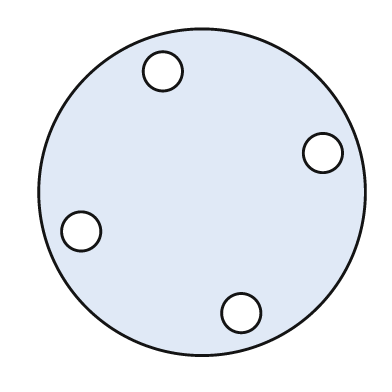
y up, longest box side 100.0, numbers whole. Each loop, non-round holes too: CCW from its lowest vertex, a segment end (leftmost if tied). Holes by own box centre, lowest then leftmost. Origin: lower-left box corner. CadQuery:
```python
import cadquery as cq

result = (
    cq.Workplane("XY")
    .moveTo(50.0, 50.0)
    .circle(50.0)
    .moveTo(62.0, 13.0)
    .circle(6.0)
    .moveTo(13.0, 38.0)
    .circle(6.0)
    .moveTo(87.0, 62.0)
    .circle(6.0)
    .moveTo(38.0, 87.0)
    .circle(6.0)
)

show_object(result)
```